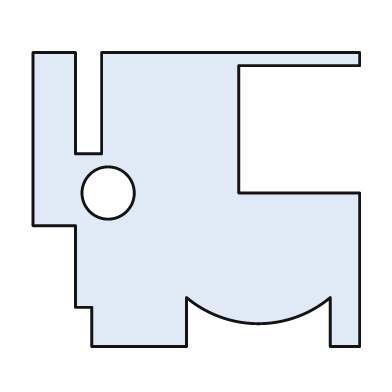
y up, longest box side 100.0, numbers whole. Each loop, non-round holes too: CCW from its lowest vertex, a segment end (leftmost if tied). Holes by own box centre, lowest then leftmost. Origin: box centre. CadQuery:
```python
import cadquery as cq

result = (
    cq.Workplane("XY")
    .moveTo(-32.0, -45.0)
    .lineTo(-3.0, -45.0)
    .lineTo(-3.0, -30.0)
    .threePointArc((19.0, -38.0), (41.0, -30.0))
    .lineTo(41.0, -45.0)
    .lineTo(50.0, -45.0)
    .lineTo(50.0, 2.0)
    .lineTo(13.0, 2.0)
    .lineTo(13.0, 41.0)
    .lineTo(50.0, 41.0)
    .lineTo(50.0, 45.0)
    .lineTo(-29.0, 45.0)
    .lineTo(-29.0, 14.0)
    .lineTo(-37.0, 14.0)
    .lineTo(-37.0, 45.0)
    .lineTo(-50.0, 45.0)
    .lineTo(-50.0, -8.0)
    .lineTo(-37.0, -8.0)
    .lineTo(-37.0, -33.0)
    .lineTo(-32.0, -33.0)
    .close()
    .moveTo(-27.0, 2.0)
    .circle(8.0)
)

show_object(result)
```